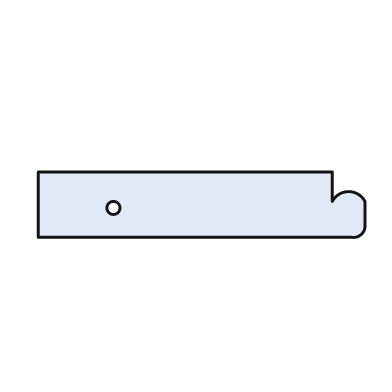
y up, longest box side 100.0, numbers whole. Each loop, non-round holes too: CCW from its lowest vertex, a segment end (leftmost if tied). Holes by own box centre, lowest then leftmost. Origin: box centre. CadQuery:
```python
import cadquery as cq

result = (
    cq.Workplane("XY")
    .moveTo(-50.0, -10.0)
    .lineTo(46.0, -10.0)
    .threePointArc((49.0, -9.0), (50.0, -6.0))
    .lineTo(50.0, 1.0)
    .threePointArc((45.0, 4.0), (40.0, 1.0))
    .lineTo(40.0, 10.0)
    .lineTo(-50.0, 10.0)
    .close()
    .moveTo(-27.0, -1.0)
    .circle(2.0)
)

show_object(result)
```